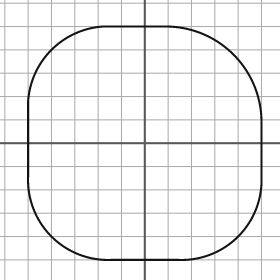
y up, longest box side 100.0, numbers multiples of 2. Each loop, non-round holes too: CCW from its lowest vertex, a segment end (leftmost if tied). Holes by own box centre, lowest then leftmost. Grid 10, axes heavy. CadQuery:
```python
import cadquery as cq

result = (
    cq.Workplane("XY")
    .moveTo(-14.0, -50.0)
    .lineTo(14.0, -50.0)
    .threePointArc((40.0, -40.0), (50.0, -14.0))
    .lineTo(50.0, 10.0)
    .threePointArc((38.0, 38.0), (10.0, 50.0))
    .lineTo(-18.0, 50.0)
    .threePointArc((-40.0, 40.0), (-50.0, 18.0))
    .lineTo(-50.0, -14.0)
    .threePointArc((-40.0, -40.0), (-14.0, -50.0))
    .close()
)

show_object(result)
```